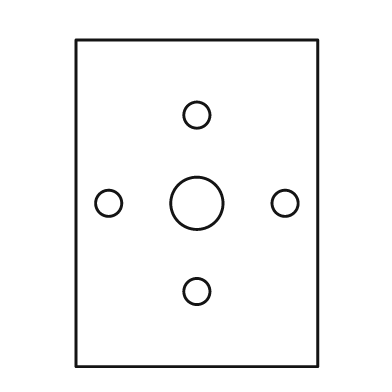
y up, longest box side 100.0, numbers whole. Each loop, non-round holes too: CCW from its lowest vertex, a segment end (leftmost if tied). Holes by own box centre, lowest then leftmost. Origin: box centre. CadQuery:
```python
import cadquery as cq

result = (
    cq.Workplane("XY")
    .moveTo(-37.0, -50.0)
    .lineTo(37.0, -50.0)
    .lineTo(37.0, 50.0)
    .lineTo(-37.0, 50.0)
    .close()
    .moveTo(0.0, -27.0)
    .circle(4.0)
    .moveTo(-27.0, 0.0)
    .circle(4.0)
    .moveTo(0.0, 0.0)
    .circle(8.0)
    .moveTo(27.0, 0.0)
    .circle(4.0)
    .moveTo(0.0, 27.0)
    .circle(4.0)
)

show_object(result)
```